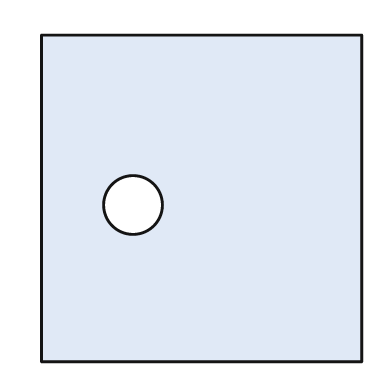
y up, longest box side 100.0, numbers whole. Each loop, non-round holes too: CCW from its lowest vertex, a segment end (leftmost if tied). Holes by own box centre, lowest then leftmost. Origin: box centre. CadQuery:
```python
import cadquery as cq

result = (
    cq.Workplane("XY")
    .moveTo(-49.0, -50.0)
    .lineTo(49.0, -50.0)
    .lineTo(49.0, 50.0)
    .lineTo(-49.0, 50.0)
    .close()
    .moveTo(-21.0, -2.0)
    .circle(9.0)
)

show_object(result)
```